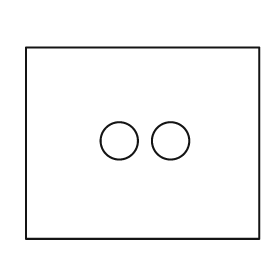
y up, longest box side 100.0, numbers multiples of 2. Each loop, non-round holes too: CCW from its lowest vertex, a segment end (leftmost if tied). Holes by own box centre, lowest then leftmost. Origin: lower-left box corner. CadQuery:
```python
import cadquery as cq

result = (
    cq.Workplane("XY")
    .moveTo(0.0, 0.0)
    .lineTo(100.0, 0.0)
    .lineTo(100.0, 82.0)
    .lineTo(0.0, 82.0)
    .close()
    .moveTo(40.0, 42.0)
    .circle(8.0)
    .moveTo(62.0, 42.0)
    .circle(8.0)
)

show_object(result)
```